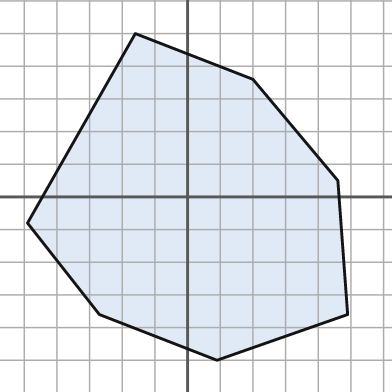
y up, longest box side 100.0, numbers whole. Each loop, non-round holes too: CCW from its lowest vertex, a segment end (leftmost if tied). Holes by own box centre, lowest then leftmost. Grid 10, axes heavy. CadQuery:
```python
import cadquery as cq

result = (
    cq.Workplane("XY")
    .moveTo(9.0, -50.0)
    .lineTo(49.0, -36.0)
    .lineTo(46.0, 5.0)
    .lineTo(20.0, 36.0)
    .lineTo(-16.0, 50.0)
    .lineTo(-49.0, -8.0)
    .lineTo(-27.0, -36.0)
    .close()
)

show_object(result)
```